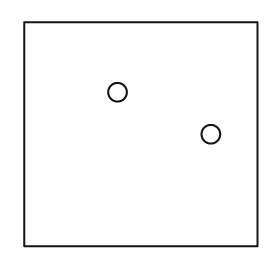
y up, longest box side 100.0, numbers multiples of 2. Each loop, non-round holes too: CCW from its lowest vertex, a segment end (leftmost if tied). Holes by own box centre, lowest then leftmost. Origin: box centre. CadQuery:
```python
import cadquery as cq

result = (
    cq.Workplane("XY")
    .moveTo(-50.0, -48.0)
    .lineTo(50.0, -48.0)
    .lineTo(50.0, 48.0)
    .lineTo(-50.0, 48.0)
    .close()
    .moveTo(30.0, 0.0)
    .circle(4.0)
    .moveTo(-10.0, 18.0)
    .circle(4.0)
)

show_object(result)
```